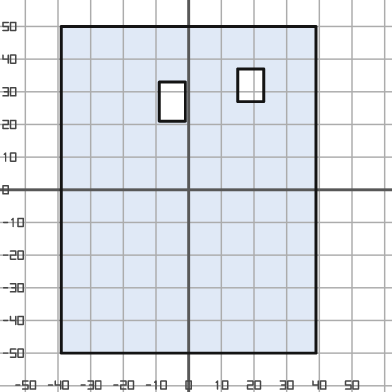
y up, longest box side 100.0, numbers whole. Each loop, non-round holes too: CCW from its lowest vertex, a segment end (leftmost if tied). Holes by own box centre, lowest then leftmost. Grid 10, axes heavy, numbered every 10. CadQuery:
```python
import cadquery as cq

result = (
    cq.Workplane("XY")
    .moveTo(-39.0, -50.0)
    .lineTo(39.0, -50.0)
    .lineTo(39.0, 50.0)
    .lineTo(-39.0, 50.0)
    .close()
    .moveTo(-9.0, 21.0)
    .lineTo(-1.0, 21.0)
    .lineTo(-1.0, 33.0)
    .lineTo(-9.0, 33.0)
    .close()
    .moveTo(15.0, 27.0)
    .lineTo(23.0, 27.0)
    .lineTo(23.0, 37.0)
    .lineTo(15.0, 37.0)
    .close()
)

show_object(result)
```